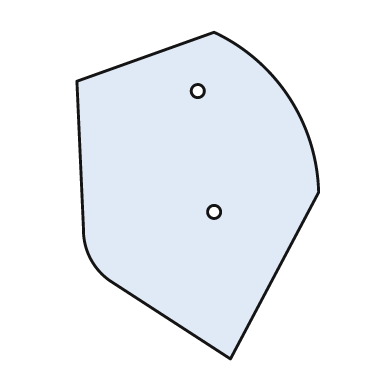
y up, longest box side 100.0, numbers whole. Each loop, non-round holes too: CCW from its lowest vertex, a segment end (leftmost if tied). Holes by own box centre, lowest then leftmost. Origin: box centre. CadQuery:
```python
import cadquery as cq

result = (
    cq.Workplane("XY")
    .moveTo(10.0, -50.0)
    .lineTo(37.0, 1.0)
    .threePointArc((28.0, 30.0), (5.0, 50.0))
    .lineTo(-37.0, 35.0)
    .lineTo(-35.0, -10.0)
    .threePointArc((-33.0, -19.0), (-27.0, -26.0))
    .close()
    .moveTo(5.0, -5.0)
    .circle(2.0)
    .moveTo(0.0, 32.0)
    .circle(2.0)
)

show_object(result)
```